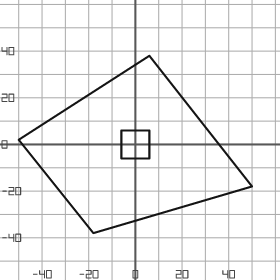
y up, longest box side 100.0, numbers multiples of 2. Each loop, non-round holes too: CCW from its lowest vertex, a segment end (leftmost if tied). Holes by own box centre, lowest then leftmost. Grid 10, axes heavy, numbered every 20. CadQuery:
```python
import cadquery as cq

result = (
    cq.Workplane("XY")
    .moveTo(-18.0, -38.0)
    .lineTo(50.0, -18.0)
    .lineTo(6.0, 38.0)
    .lineTo(-50.0, 2.0)
    .close()
    .moveTo(-6.0, -6.0)
    .lineTo(6.0, -6.0)
    .lineTo(6.0, 6.0)
    .lineTo(-6.0, 6.0)
    .close()
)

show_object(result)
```